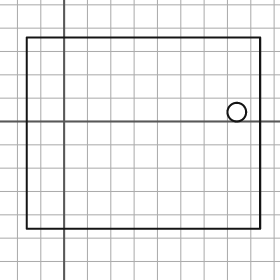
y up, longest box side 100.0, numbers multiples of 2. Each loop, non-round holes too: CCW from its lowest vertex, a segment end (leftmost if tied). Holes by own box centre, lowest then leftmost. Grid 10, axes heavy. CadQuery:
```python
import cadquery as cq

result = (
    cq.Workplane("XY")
    .moveTo(-16.0, -46.0)
    .lineTo(84.0, -46.0)
    .lineTo(84.0, 36.0)
    .lineTo(-16.0, 36.0)
    .close()
    .moveTo(74.0, 4.0)
    .circle(4.0)
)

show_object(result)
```